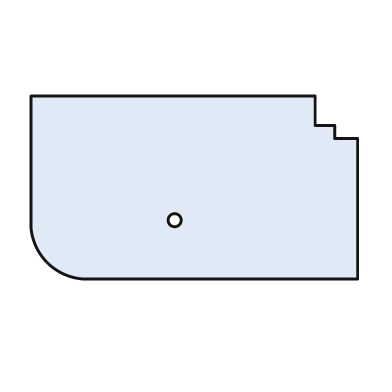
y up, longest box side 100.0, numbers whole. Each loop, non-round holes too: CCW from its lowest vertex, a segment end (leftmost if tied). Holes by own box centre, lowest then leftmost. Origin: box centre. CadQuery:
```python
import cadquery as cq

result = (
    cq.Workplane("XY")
    .moveTo(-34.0, -28.0)
    .lineTo(50.0, -28.0)
    .lineTo(50.0, 15.0)
    .lineTo(43.0, 15.0)
    .lineTo(43.0, 19.0)
    .lineTo(37.0, 19.0)
    .lineTo(37.0, 28.0)
    .lineTo(-50.0, 28.0)
    .lineTo(-50.0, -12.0)
    .threePointArc((-45.0, -23.0), (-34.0, -28.0))
    .close()
    .moveTo(-6.0, -10.0)
    .circle(2.0)
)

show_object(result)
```